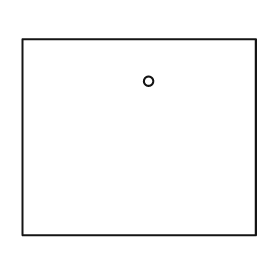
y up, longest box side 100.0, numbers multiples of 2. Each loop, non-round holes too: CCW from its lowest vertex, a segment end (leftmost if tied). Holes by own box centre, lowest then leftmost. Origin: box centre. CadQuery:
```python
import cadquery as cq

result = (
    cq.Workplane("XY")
    .moveTo(-50.0, -42.0)
    .lineTo(50.0, -42.0)
    .lineTo(50.0, 42.0)
    .lineTo(-50.0, 42.0)
    .close()
    .moveTo(4.0, 24.0)
    .circle(2.0)
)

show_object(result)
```